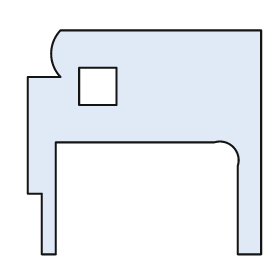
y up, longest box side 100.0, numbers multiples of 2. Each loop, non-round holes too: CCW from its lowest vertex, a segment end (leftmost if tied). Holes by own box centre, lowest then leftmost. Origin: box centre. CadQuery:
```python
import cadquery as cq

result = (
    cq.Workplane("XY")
    .moveTo(-44.0, -48.0)
    .lineTo(-38.0, -48.0)
    .lineTo(-38.0, 0.0)
    .lineTo(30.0, 0.0)
    .threePointArc((38.0, -2.0), (40.0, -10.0))
    .lineTo(40.0, -48.0)
    .lineTo(50.0, -48.0)
    .lineTo(50.0, 48.0)
    .lineTo(-36.0, 48.0)
    .threePointArc((-40.0, 38.0), (-36.0, 28.0))
    .lineTo(-50.0, 28.0)
    .lineTo(-50.0, -22.0)
    .lineTo(-44.0, -22.0)
    .close()
    .moveTo(-28.0, 16.0)
    .lineTo(-12.0, 16.0)
    .lineTo(-12.0, 32.0)
    .lineTo(-28.0, 32.0)
    .close()
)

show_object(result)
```